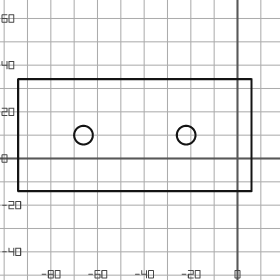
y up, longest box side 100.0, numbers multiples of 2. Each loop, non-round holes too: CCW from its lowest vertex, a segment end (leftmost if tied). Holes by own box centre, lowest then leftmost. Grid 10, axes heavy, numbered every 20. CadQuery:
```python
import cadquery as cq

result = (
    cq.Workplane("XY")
    .moveTo(-94.0, -14.0)
    .lineTo(6.0, -14.0)
    .lineTo(6.0, 34.0)
    .lineTo(-94.0, 34.0)
    .close()
    .moveTo(-66.0, 10.0)
    .circle(4.0)
    .moveTo(-22.0, 10.0)
    .circle(4.0)
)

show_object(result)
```